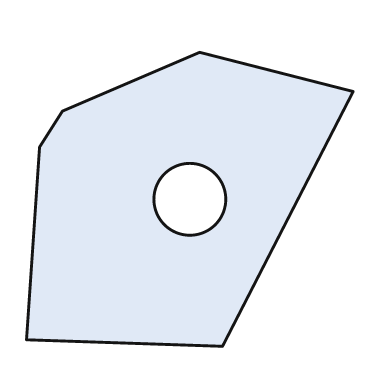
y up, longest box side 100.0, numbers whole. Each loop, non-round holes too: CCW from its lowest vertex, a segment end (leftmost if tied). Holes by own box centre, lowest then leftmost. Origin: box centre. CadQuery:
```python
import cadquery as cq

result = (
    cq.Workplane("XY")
    .moveTo(10.0, -45.0)
    .lineTo(50.0, 33.0)
    .lineTo(3.0, 45.0)
    .lineTo(-39.0, 27.0)
    .lineTo(-46.0, 16.0)
    .lineTo(-50.0, -43.0)
    .close()
    .moveTo(0.0, 0.0)
    .circle(11.0)
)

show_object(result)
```